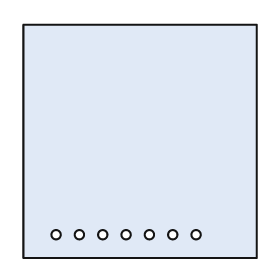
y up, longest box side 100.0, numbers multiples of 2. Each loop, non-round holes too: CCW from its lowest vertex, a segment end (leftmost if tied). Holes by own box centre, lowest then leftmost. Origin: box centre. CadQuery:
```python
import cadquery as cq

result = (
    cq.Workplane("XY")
    .moveTo(-50.0, -50.0)
    .lineTo(50.0, -50.0)
    .lineTo(50.0, 50.0)
    .lineTo(-50.0, 50.0)
    .close()
    .moveTo(-36.0, -40.0)
    .circle(2.0)
    .moveTo(-26.0, -40.0)
    .circle(2.0)
    .moveTo(-16.0, -40.0)
    .circle(2.0)
    .moveTo(-6.0, -40.0)
    .circle(2.0)
    .moveTo(4.0, -40.0)
    .circle(2.0)
    .moveTo(14.0, -40.0)
    .circle(2.0)
    .moveTo(24.0, -40.0)
    .circle(2.0)
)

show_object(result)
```